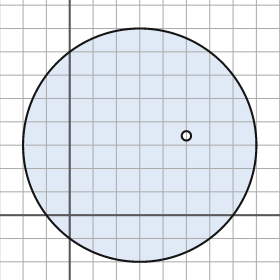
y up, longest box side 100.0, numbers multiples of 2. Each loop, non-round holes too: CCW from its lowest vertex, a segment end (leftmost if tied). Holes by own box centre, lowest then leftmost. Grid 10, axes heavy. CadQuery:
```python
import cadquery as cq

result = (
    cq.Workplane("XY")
    .moveTo(30.0, 30.0)
    .circle(50.0)
    .moveTo(50.0, 34.0)
    .circle(2.0)
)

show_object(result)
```